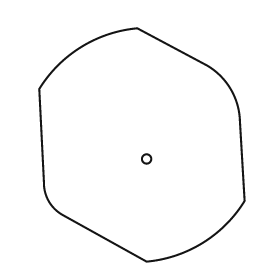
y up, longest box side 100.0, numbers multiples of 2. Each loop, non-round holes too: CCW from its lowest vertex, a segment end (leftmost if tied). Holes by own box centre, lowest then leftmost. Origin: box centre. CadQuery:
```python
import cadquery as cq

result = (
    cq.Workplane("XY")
    .moveTo(2.0, -50.0)
    .threePointArc((26.0, -42.0), (44.0, -24.0))
    .lineTo(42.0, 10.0)
    .threePointArc((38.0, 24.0), (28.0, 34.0))
    .lineTo(-2.0, 50.0)
    .threePointArc((-26.0, 42.0), (-44.0, 24.0))
    .lineTo(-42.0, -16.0)
    .threePointArc((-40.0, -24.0), (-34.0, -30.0))
    .close()
    .moveTo(2.0, -6.0)
    .circle(2.0)
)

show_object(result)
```